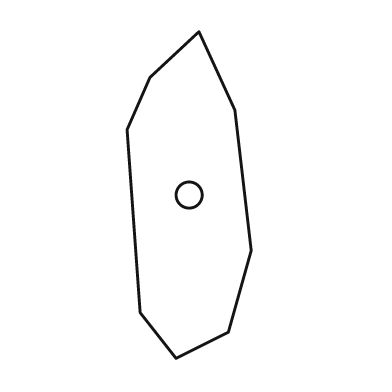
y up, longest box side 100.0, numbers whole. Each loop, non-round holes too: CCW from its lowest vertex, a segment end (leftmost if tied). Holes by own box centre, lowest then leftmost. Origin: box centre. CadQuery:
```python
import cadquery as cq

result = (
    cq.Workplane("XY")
    .moveTo(-4.0, -50.0)
    .lineTo(12.0, -42.0)
    .lineTo(19.0, -17.0)
    .lineTo(14.0, 26.0)
    .lineTo(3.0, 50.0)
    .lineTo(-12.0, 36.0)
    .lineTo(-19.0, 20.0)
    .lineTo(-15.0, -36.0)
    .close()
    .moveTo(0.0, 0.0)
    .circle(4.0)
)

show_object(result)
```